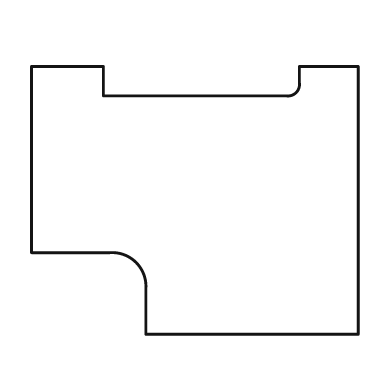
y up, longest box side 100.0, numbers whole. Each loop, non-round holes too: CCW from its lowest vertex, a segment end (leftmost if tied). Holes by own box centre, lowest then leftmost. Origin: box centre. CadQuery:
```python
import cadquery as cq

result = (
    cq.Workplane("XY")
    .moveTo(-15.0, -41.0)
    .lineTo(50.0, -41.0)
    .lineTo(50.0, 41.0)
    .lineTo(32.0, 41.0)
    .lineTo(32.0, 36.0)
    .threePointArc((31.0, 33.0), (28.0, 32.0))
    .lineTo(-28.0, 32.0)
    .lineTo(-28.0, 41.0)
    .lineTo(-50.0, 41.0)
    .lineTo(-50.0, -16.0)
    .lineTo(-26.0, -16.0)
    .threePointArc((-18.0, -19.0), (-15.0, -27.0))
    .close()
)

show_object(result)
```